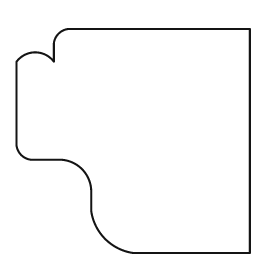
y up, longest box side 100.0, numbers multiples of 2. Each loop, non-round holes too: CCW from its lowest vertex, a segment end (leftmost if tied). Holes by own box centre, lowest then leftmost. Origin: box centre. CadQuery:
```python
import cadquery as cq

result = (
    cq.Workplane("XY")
    .moveTo(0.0, -48.0)
    .lineTo(50.0, -48.0)
    .lineTo(50.0, 48.0)
    .lineTo(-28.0, 48.0)
    .threePointArc((-32.0, 46.0), (-34.0, 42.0))
    .lineTo(-34.0, 34.0)
    .threePointArc((-42.0, 38.0), (-50.0, 34.0))
    .lineTo(-50.0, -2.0)
    .threePointArc((-48.0, -6.0), (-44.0, -8.0))
    .lineTo(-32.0, -8.0)
    .threePointArc((-22.0, -12.0), (-18.0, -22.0))
    .lineTo(-18.0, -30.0)
    .threePointArc((-12.0, -42.0), (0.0, -48.0))
    .close()
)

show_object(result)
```